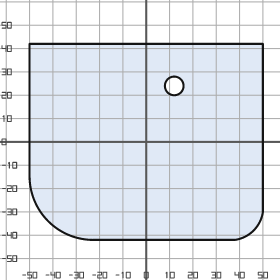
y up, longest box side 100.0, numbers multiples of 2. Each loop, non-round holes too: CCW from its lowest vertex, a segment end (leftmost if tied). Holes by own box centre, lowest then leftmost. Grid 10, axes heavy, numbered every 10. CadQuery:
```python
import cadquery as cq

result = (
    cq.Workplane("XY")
    .moveTo(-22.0, -42.0)
    .lineTo(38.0, -42.0)
    .threePointArc((46.0, -38.0), (50.0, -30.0))
    .lineTo(50.0, 42.0)
    .lineTo(-50.0, 42.0)
    .lineTo(-50.0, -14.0)
    .threePointArc((-42.0, -34.0), (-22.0, -42.0))
    .close()
    .moveTo(12.0, 24.0)
    .circle(4.0)
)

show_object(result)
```